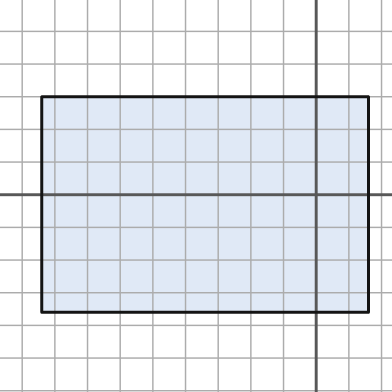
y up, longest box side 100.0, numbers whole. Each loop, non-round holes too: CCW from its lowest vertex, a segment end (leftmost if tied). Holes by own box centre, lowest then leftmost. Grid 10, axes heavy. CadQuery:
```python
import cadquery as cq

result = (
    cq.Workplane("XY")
    .moveTo(-84.0, -36.0)
    .lineTo(16.0, -36.0)
    .lineTo(16.0, 30.0)
    .lineTo(-84.0, 30.0)
    .close()
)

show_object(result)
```